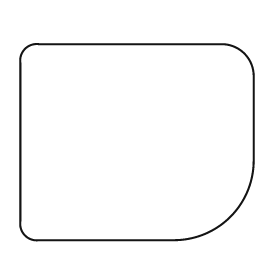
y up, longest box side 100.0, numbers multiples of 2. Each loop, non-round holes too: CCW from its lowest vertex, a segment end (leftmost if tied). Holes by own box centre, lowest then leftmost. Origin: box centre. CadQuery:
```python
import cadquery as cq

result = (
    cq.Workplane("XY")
    .moveTo(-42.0, -42.0)
    .lineTo(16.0, -42.0)
    .threePointArc((40.0, -32.0), (50.0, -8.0))
    .lineTo(50.0, 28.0)
    .threePointArc((46.0, 38.0), (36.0, 42.0))
    .lineTo(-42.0, 42.0)
    .threePointArc((-48.0, 40.0), (-50.0, 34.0))
    .lineTo(-50.0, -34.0)
    .threePointArc((-48.0, -40.0), (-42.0, -42.0))
    .close()
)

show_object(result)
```